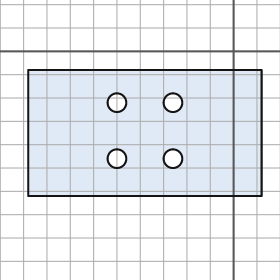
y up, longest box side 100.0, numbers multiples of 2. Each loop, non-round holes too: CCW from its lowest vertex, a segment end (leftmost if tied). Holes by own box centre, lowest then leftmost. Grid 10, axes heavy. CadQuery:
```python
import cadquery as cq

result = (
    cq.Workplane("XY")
    .moveTo(-88.0, -62.0)
    .lineTo(12.0, -62.0)
    .lineTo(12.0, -8.0)
    .lineTo(-88.0, -8.0)
    .close()
    .moveTo(-50.0, -46.0)
    .circle(4.0)
    .moveTo(-26.0, -46.0)
    .circle(4.0)
    .moveTo(-50.0, -22.0)
    .circle(4.0)
    .moveTo(-26.0, -22.0)
    .circle(4.0)
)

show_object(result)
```